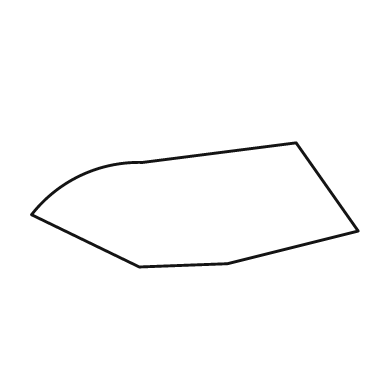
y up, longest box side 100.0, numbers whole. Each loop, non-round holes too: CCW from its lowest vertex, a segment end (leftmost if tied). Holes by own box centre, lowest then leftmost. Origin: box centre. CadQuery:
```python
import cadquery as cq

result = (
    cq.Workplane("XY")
    .moveTo(-17.0, -19.0)
    .lineTo(10.0, -18.0)
    .lineTo(50.0, -8.0)
    .lineTo(31.0, 19.0)
    .lineTo(-16.0, 13.0)
    .threePointArc((-35.0, 9.0), (-50.0, -3.0))
    .close()
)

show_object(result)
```